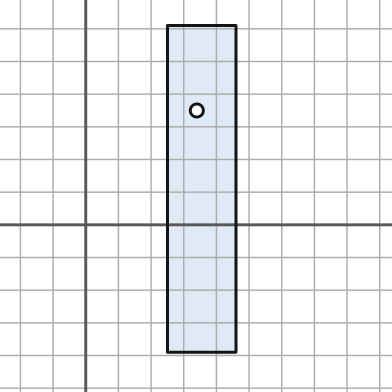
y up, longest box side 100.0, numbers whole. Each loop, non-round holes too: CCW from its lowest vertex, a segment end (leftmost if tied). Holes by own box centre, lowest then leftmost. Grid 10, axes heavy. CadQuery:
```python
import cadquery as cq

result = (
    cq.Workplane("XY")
    .moveTo(25.0, -39.0)
    .lineTo(46.0, -39.0)
    .lineTo(46.0, 61.0)
    .lineTo(25.0, 61.0)
    .close()
    .moveTo(34.0, 35.0)
    .circle(2.0)
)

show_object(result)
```